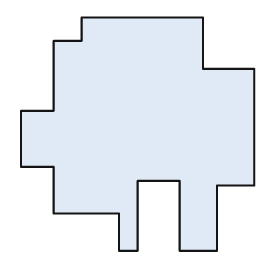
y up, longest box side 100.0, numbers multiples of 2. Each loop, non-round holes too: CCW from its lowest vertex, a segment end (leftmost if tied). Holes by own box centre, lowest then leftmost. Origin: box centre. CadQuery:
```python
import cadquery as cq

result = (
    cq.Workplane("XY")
    .moveTo(-8.0, -50.0)
    .lineTo(0.0, -50.0)
    .lineTo(0.0, -20.0)
    .lineTo(18.0, -20.0)
    .lineTo(18.0, -50.0)
    .lineTo(34.0, -50.0)
    .lineTo(34.0, -22.0)
    .lineTo(50.0, -22.0)
    .lineTo(50.0, 28.0)
    .lineTo(28.0, 28.0)
    .lineTo(28.0, 50.0)
    .lineTo(-24.0, 50.0)
    .lineTo(-24.0, 40.0)
    .lineTo(-36.0, 40.0)
    .lineTo(-36.0, 10.0)
    .lineTo(-50.0, 10.0)
    .lineTo(-50.0, -14.0)
    .lineTo(-36.0, -14.0)
    .lineTo(-36.0, -34.0)
    .lineTo(-8.0, -34.0)
    .close()
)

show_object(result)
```